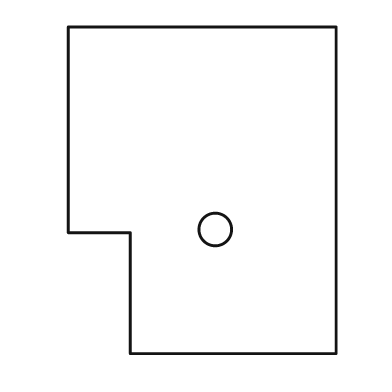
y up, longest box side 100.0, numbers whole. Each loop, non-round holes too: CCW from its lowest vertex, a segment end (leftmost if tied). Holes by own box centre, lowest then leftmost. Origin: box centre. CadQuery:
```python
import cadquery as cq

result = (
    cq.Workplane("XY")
    .moveTo(-22.0, -50.0)
    .lineTo(41.0, -50.0)
    .lineTo(41.0, 50.0)
    .lineTo(-41.0, 50.0)
    .lineTo(-41.0, -13.0)
    .lineTo(-22.0, -13.0)
    .close()
    .moveTo(4.0, -12.0)
    .circle(5.0)
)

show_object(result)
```